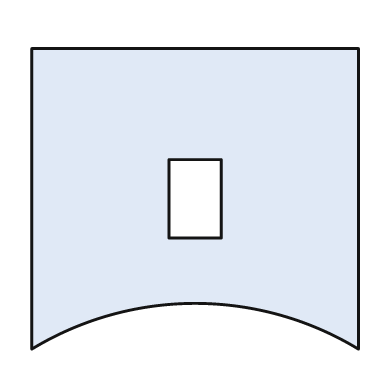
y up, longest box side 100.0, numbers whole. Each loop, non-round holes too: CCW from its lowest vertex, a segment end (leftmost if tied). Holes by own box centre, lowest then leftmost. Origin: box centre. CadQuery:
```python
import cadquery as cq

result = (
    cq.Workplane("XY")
    .moveTo(-50.0, -46.0)
    .threePointArc((0.0, -32.0), (50.0, -46.0))
    .lineTo(50.0, 46.0)
    .lineTo(-50.0, 46.0)
    .close()
    .moveTo(-8.0, -12.0)
    .lineTo(8.0, -12.0)
    .lineTo(8.0, 12.0)
    .lineTo(-8.0, 12.0)
    .close()
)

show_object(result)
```